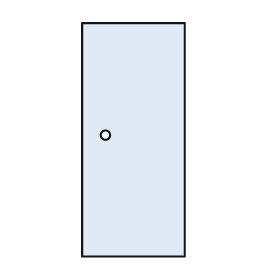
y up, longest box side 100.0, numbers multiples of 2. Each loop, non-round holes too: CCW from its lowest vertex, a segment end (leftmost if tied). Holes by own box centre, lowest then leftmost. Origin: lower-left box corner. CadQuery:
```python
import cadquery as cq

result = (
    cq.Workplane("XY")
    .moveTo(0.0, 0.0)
    .lineTo(44.0, 0.0)
    .lineTo(44.0, 100.0)
    .lineTo(0.0, 100.0)
    .close()
    .moveTo(10.0, 52.0)
    .circle(2.0)
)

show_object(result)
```